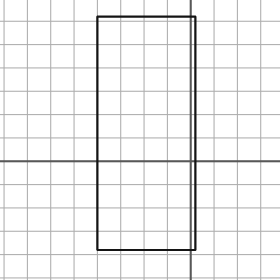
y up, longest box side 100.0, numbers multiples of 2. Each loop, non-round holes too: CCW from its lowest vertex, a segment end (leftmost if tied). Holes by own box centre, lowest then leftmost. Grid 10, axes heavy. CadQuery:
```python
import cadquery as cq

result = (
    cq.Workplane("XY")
    .moveTo(-40.0, -38.0)
    .lineTo(2.0, -38.0)
    .lineTo(2.0, 62.0)
    .lineTo(-40.0, 62.0)
    .close()
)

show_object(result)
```